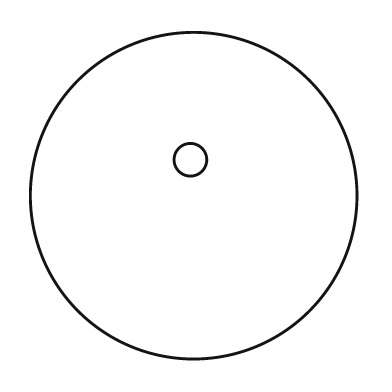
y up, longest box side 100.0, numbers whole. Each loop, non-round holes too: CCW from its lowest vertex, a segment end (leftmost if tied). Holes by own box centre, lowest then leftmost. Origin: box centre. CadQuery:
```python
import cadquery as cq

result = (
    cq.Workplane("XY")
    .moveTo(0.0, 0.0)
    .circle(50.0)
    .moveTo(-1.0, 11.0)
    .circle(5.0)
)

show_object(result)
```